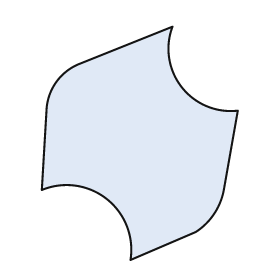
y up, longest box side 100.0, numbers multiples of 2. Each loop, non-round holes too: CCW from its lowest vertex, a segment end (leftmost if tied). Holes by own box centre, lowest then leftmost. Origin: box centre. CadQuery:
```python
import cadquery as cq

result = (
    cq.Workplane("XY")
    .moveTo(-4.0, -50.0)
    .lineTo(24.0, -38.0)
    .threePointArc((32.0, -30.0), (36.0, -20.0))
    .lineTo(42.0, 14.0)
    .threePointArc((18.0, 24.0), (14.0, 50.0))
    .lineTo(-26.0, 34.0)
    .threePointArc((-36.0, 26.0), (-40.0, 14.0))
    .lineTo(-42.0, -20.0)
    .threePointArc((-14.0, -24.0), (-4.0, -50.0))
    .close()
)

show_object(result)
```